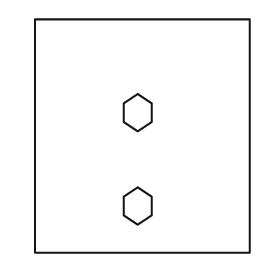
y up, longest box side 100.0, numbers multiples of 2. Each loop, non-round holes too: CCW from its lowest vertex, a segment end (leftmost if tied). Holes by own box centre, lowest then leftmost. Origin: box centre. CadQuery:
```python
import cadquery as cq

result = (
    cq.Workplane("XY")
    .moveTo(-46.0, -50.0)
    .lineTo(46.0, -50.0)
    .lineTo(46.0, 50.0)
    .lineTo(-46.0, 50.0)
    .close()
    .moveTo(-2.0, -38.0)
    .lineTo(4.0, -34.0)
    .lineTo(4.0, -26.0)
    .lineTo(-2.0, -22.0)
    .lineTo(-8.0, -26.0)
    .lineTo(-8.0, -34.0)
    .close()
    .moveTo(-2.0, 2.0)
    .lineTo(4.0, 6.0)
    .lineTo(4.0, 14.0)
    .lineTo(-2.0, 18.0)
    .lineTo(-8.0, 14.0)
    .lineTo(-8.0, 6.0)
    .close()
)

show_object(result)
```